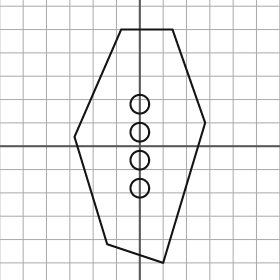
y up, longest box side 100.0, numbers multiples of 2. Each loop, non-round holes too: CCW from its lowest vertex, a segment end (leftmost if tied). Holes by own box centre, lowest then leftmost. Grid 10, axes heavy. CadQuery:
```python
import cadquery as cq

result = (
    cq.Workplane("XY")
    .moveTo(10.0, -50.0)
    .lineTo(28.0, 10.0)
    .lineTo(14.0, 50.0)
    .lineTo(-8.0, 50.0)
    .lineTo(-28.0, 4.0)
    .lineTo(-14.0, -42.0)
    .close()
    .moveTo(0.0, -18.0)
    .circle(4.0)
    .moveTo(0.0, -6.0)
    .circle(4.0)
    .moveTo(0.0, 6.0)
    .circle(4.0)
    .moveTo(0.0, 18.0)
    .circle(4.0)
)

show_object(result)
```